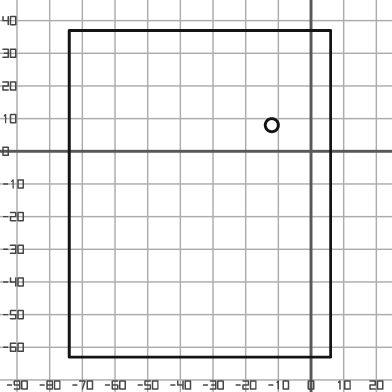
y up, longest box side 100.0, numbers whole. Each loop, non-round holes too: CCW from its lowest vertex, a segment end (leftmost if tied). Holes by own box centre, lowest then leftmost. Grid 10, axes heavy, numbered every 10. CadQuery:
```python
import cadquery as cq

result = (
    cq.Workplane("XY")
    .moveTo(-74.0, -63.0)
    .lineTo(6.0, -63.0)
    .lineTo(6.0, 37.0)
    .lineTo(-74.0, 37.0)
    .close()
    .moveTo(-12.0, 8.0)
    .circle(2.0)
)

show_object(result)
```